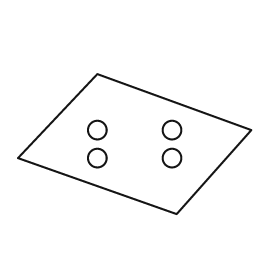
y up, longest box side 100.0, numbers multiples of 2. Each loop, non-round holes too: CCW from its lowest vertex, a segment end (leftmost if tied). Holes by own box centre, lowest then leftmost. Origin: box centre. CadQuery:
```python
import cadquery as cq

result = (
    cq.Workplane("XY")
    .moveTo(18.0, -30.0)
    .lineTo(50.0, 6.0)
    .lineTo(-16.0, 30.0)
    .lineTo(-50.0, -6.0)
    .close()
    .moveTo(-16.0, -6.0)
    .circle(4.0)
    .moveTo(16.0, -6.0)
    .circle(4.0)
    .moveTo(-16.0, 6.0)
    .circle(4.0)
    .moveTo(16.0, 6.0)
    .circle(4.0)
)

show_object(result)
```